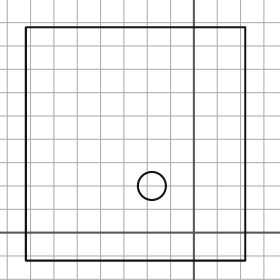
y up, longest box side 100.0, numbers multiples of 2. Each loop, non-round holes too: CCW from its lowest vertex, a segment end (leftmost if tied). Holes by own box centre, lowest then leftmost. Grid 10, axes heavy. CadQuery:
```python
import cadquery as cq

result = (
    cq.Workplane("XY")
    .moveTo(-72.0, -12.0)
    .lineTo(22.0, -12.0)
    .lineTo(22.0, 88.0)
    .lineTo(-72.0, 88.0)
    .close()
    .moveTo(-18.0, 20.0)
    .circle(6.0)
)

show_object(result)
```